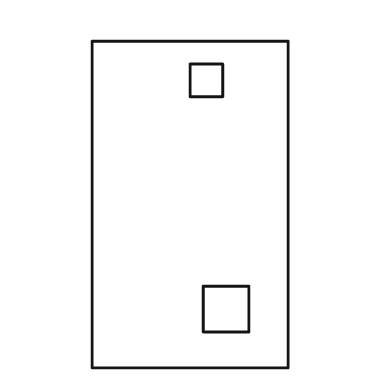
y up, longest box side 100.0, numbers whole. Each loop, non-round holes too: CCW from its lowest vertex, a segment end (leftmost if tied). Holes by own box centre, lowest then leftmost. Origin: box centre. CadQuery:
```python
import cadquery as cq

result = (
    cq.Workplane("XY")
    .moveTo(-30.0, -50.0)
    .lineTo(30.0, -50.0)
    .lineTo(30.0, 50.0)
    .lineTo(-30.0, 50.0)
    .close()
    .moveTo(4.0, -39.0)
    .lineTo(18.0, -39.0)
    .lineTo(18.0, -25.0)
    .lineTo(4.0, -25.0)
    .close()
    .moveTo(0.0, 33.0)
    .lineTo(10.0, 33.0)
    .lineTo(10.0, 43.0)
    .lineTo(0.0, 43.0)
    .close()
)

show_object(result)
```